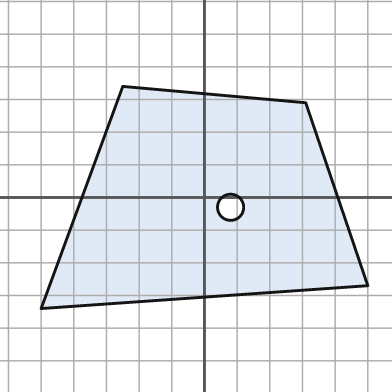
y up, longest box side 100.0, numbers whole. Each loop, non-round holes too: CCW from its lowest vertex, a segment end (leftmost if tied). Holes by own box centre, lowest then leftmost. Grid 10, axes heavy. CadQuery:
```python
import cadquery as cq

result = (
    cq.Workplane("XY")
    .moveTo(-50.0, -34.0)
    .lineTo(50.0, -27.0)
    .lineTo(31.0, 29.0)
    .lineTo(-25.0, 34.0)
    .close()
    .moveTo(8.0, -3.0)
    .circle(4.0)
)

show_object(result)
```